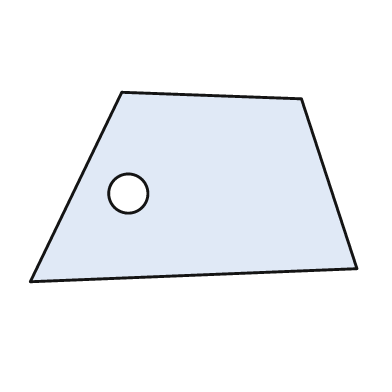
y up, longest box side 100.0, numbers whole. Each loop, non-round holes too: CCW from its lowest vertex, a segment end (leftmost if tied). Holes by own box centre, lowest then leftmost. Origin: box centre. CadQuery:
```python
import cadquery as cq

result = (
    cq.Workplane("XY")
    .moveTo(-50.0, -29.0)
    .lineTo(50.0, -25.0)
    .lineTo(33.0, 27.0)
    .lineTo(-22.0, 29.0)
    .close()
    .moveTo(-20.0, -2.0)
    .circle(6.0)
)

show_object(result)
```